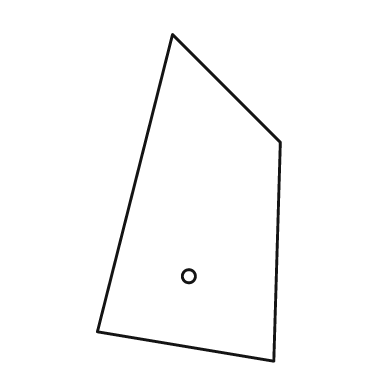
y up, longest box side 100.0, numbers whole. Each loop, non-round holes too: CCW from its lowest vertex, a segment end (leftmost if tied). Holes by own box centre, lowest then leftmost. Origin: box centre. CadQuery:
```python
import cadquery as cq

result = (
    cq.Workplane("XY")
    .moveTo(26.0, -50.0)
    .lineTo(28.0, 17.0)
    .lineTo(-5.0, 50.0)
    .lineTo(-28.0, -41.0)
    .close()
    .moveTo(0.0, -24.0)
    .circle(2.0)
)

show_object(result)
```